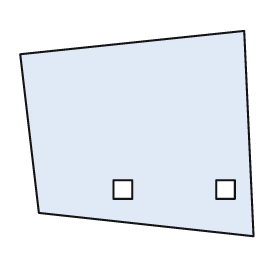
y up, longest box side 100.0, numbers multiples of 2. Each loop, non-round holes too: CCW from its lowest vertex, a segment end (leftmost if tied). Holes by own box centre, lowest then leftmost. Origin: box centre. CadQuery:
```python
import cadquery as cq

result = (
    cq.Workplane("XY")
    .moveTo(50.0, -44.0)
    .lineTo(46.0, 44.0)
    .lineTo(-50.0, 34.0)
    .lineTo(-42.0, -34.0)
    .close()
    .moveTo(-10.0, -28.0)
    .lineTo(-2.0, -28.0)
    .lineTo(-2.0, -20.0)
    .lineTo(-10.0, -20.0)
    .close()
    .moveTo(34.0, -28.0)
    .lineTo(42.0, -28.0)
    .lineTo(42.0, -20.0)
    .lineTo(34.0, -20.0)
    .close()
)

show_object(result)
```